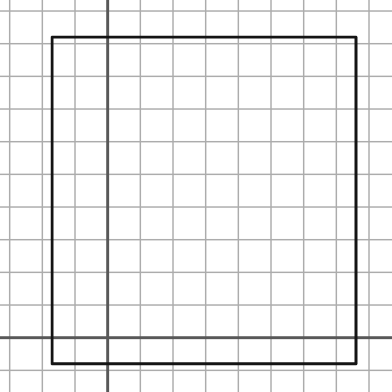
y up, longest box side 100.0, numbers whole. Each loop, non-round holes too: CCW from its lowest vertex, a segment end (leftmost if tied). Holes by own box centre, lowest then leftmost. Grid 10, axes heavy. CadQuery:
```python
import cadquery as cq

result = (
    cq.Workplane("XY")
    .moveTo(-17.0, -8.0)
    .lineTo(76.0, -8.0)
    .lineTo(76.0, 92.0)
    .lineTo(-17.0, 92.0)
    .close()
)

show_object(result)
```